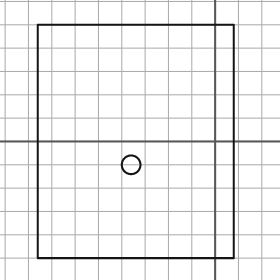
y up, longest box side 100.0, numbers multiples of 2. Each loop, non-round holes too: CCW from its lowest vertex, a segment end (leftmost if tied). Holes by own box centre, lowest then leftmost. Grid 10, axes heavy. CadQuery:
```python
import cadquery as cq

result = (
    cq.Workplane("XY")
    .moveTo(-76.0, -50.0)
    .lineTo(8.0, -50.0)
    .lineTo(8.0, 50.0)
    .lineTo(-76.0, 50.0)
    .close()
    .moveTo(-36.0, -10.0)
    .circle(4.0)
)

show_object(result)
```